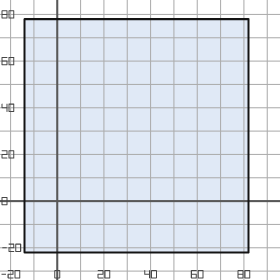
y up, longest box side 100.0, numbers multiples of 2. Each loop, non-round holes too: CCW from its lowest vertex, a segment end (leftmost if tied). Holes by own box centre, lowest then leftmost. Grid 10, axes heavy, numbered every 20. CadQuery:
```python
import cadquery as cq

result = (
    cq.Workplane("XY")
    .moveTo(-14.0, -22.0)
    .lineTo(82.0, -22.0)
    .lineTo(82.0, 78.0)
    .lineTo(-14.0, 78.0)
    .close()
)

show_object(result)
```